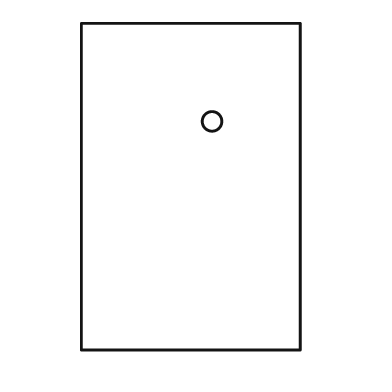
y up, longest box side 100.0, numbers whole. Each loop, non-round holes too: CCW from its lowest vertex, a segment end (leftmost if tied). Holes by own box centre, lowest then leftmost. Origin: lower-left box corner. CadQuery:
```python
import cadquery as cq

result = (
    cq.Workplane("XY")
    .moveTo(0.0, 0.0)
    .lineTo(67.0, 0.0)
    .lineTo(67.0, 100.0)
    .lineTo(0.0, 100.0)
    .close()
    .moveTo(40.0, 70.0)
    .circle(3.0)
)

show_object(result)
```